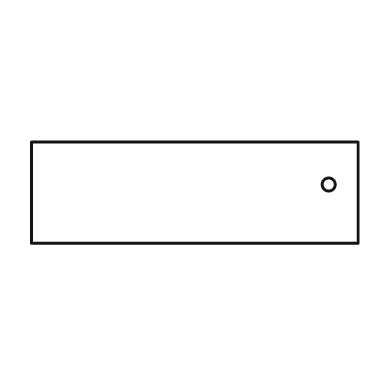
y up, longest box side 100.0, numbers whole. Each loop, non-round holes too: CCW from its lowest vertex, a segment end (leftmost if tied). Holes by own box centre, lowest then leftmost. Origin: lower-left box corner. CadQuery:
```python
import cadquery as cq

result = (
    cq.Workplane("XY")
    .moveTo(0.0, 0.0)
    .lineTo(100.0, 0.0)
    .lineTo(100.0, 31.0)
    .lineTo(0.0, 31.0)
    .close()
    .moveTo(91.0, 18.0)
    .circle(2.0)
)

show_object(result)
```